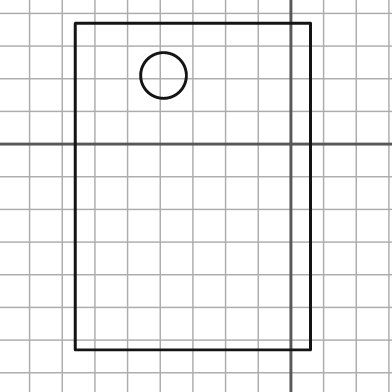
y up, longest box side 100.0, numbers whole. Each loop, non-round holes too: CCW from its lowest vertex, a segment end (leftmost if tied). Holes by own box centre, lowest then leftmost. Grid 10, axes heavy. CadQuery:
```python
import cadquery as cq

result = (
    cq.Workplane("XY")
    .moveTo(-66.0, -63.0)
    .lineTo(6.0, -63.0)
    .lineTo(6.0, 37.0)
    .lineTo(-66.0, 37.0)
    .close()
    .moveTo(-39.0, 21.0)
    .circle(7.0)
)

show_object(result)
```